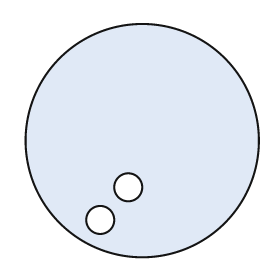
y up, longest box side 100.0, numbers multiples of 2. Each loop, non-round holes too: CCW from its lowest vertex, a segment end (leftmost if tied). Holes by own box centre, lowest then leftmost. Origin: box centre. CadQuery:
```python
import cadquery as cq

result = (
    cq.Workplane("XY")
    .moveTo(0.0, 0.0)
    .circle(50.0)
    .moveTo(-18.0, -34.0)
    .circle(6.0)
    .moveTo(-6.0, -20.0)
    .circle(6.0)
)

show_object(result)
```